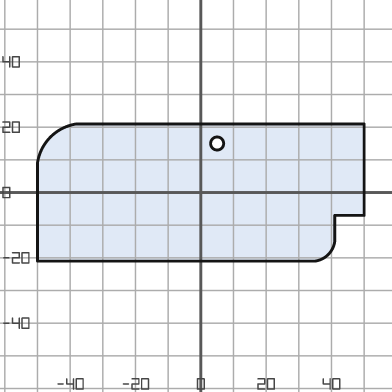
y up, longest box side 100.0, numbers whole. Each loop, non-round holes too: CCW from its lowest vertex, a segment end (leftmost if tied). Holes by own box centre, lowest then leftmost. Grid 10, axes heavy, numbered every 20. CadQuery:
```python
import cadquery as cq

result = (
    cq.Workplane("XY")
    .moveTo(-50.0, -21.0)
    .lineTo(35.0, -21.0)
    .threePointArc((39.0, -19.0), (41.0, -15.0))
    .lineTo(41.0, -7.0)
    .lineTo(50.0, -7.0)
    .lineTo(50.0, 21.0)
    .lineTo(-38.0, 21.0)
    .threePointArc((-46.0, 17.0), (-50.0, 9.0))
    .close()
    .moveTo(5.0, 15.0)
    .circle(2.0)
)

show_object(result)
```